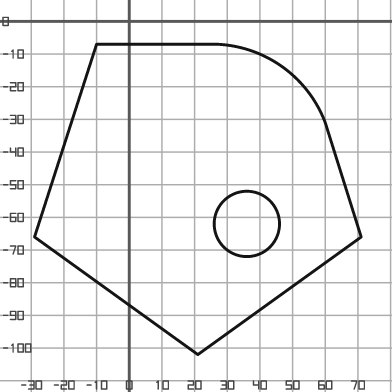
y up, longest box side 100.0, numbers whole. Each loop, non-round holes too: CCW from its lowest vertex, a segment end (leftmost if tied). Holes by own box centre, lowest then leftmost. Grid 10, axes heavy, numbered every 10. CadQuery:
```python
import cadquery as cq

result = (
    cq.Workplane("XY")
    .moveTo(21.0, -102.0)
    .lineTo(71.0, -66.0)
    .lineTo(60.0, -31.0)
    .threePointArc((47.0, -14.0), (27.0, -7.0))
    .lineTo(-10.0, -7.0)
    .lineTo(-29.0, -66.0)
    .close()
    .moveTo(36.0, -62.0)
    .circle(10.0)
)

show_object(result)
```